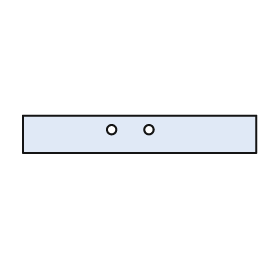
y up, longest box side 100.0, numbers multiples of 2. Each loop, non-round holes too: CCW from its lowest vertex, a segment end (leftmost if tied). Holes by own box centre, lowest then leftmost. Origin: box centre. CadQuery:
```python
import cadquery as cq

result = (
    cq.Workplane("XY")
    .moveTo(-50.0, -8.0)
    .lineTo(50.0, -8.0)
    .lineTo(50.0, 8.0)
    .lineTo(-50.0, 8.0)
    .close()
    .moveTo(-12.0, 2.0)
    .circle(2.0)
    .moveTo(4.0, 2.0)
    .circle(2.0)
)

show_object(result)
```